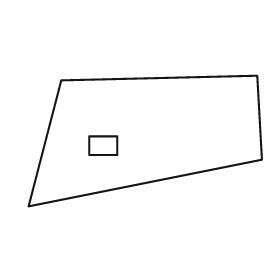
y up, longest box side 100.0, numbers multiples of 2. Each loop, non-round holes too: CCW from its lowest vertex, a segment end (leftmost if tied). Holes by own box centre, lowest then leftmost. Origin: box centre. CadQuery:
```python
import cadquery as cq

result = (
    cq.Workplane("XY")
    .moveTo(-50.0, -28.0)
    .lineTo(50.0, -8.0)
    .lineTo(48.0, 28.0)
    .lineTo(-36.0, 26.0)
    .close()
    .moveTo(-24.0, -6.0)
    .lineTo(-12.0, -6.0)
    .lineTo(-12.0, 2.0)
    .lineTo(-24.0, 2.0)
    .close()
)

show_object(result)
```